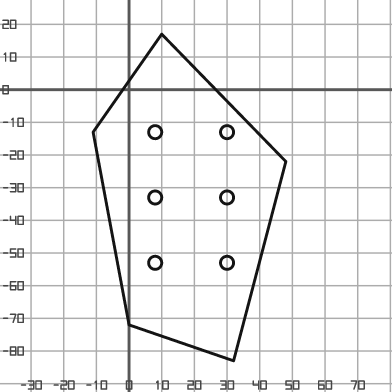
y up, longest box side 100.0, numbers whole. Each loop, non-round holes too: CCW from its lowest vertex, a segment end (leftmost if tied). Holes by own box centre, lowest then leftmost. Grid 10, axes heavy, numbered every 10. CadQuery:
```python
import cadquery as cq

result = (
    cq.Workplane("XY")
    .moveTo(32.0, -83.0)
    .lineTo(48.0, -22.0)
    .lineTo(10.0, 17.0)
    .lineTo(-11.0, -13.0)
    .lineTo(0.0, -72.0)
    .close()
    .moveTo(8.0, -53.0)
    .circle(2.0)
    .moveTo(30.0, -53.0)
    .circle(2.0)
    .moveTo(8.0, -33.0)
    .circle(2.0)
    .moveTo(30.0, -33.0)
    .circle(2.0)
    .moveTo(8.0, -13.0)
    .circle(2.0)
    .moveTo(30.0, -13.0)
    .circle(2.0)
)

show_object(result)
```